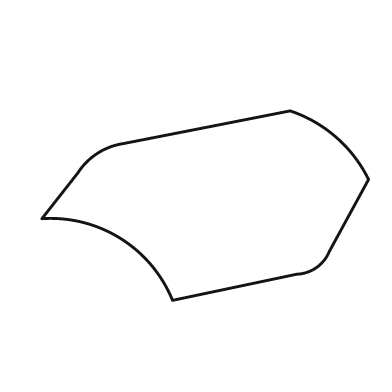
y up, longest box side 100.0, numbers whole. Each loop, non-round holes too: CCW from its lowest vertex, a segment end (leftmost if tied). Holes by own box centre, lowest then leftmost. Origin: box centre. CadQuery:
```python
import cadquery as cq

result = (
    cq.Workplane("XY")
    .moveTo(-10.0, -29.0)
    .lineTo(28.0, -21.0)
    .threePointArc((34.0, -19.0), (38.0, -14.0))
    .lineTo(50.0, 8.0)
    .threePointArc((40.0, 21.0), (26.0, 29.0))
    .lineTo(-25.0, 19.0)
    .threePointArc((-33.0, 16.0), (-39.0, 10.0))
    .lineTo(-50.0, -4.0)
    .threePointArc((-26.0, -10.0), (-10.0, -29.0))
    .close()
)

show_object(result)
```